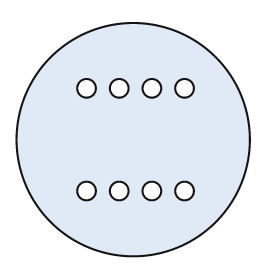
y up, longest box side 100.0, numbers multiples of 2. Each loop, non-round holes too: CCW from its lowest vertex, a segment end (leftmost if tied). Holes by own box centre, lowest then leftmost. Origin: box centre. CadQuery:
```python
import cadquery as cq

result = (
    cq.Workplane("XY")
    .moveTo(0.0, 0.0)
    .circle(50.0)
    .moveTo(-20.0, -22.0)
    .circle(4.0)
    .moveTo(-6.0, -22.0)
    .circle(4.0)
    .moveTo(8.0, -22.0)
    .circle(4.0)
    .moveTo(22.0, -22.0)
    .circle(4.0)
    .moveTo(-20.0, 22.0)
    .circle(4.0)
    .moveTo(-6.0, 22.0)
    .circle(4.0)
    .moveTo(8.0, 22.0)
    .circle(4.0)
    .moveTo(22.0, 22.0)
    .circle(4.0)
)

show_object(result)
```